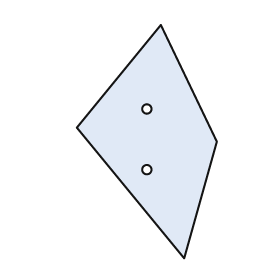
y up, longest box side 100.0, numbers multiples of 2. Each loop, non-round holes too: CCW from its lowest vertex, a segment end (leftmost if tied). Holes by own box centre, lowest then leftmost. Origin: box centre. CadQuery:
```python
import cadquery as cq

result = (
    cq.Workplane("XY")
    .moveTo(16.0, -50.0)
    .lineTo(30.0, 0.0)
    .lineTo(6.0, 50.0)
    .lineTo(-30.0, 6.0)
    .close()
    .moveTo(0.0, -12.0)
    .circle(2.0)
    .moveTo(0.0, 14.0)
    .circle(2.0)
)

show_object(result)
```